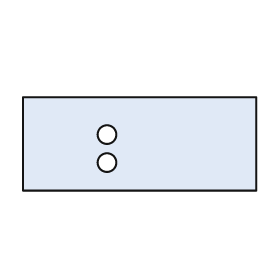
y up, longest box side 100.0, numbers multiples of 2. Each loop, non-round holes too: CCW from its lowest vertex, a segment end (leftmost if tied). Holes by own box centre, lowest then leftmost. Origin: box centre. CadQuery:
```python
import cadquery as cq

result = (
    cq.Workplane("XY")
    .moveTo(-50.0, -20.0)
    .lineTo(50.0, -20.0)
    .lineTo(50.0, 20.0)
    .lineTo(-50.0, 20.0)
    .close()
    .moveTo(-14.0, -8.0)
    .circle(4.0)
    .moveTo(-14.0, 4.0)
    .circle(4.0)
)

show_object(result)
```